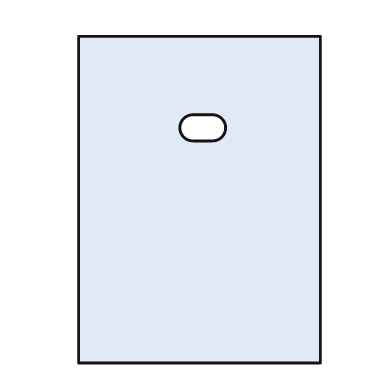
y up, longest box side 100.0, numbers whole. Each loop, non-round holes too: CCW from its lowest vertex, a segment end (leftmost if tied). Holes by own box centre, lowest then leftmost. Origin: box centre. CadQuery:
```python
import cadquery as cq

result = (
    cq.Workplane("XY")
    .moveTo(-37.0, -50.0)
    .lineTo(37.0, -50.0)
    .lineTo(37.0, 50.0)
    .lineTo(-37.0, 50.0)
    .close()
    .moveTo(-2.0, 18.0)
    .lineTo(4.0, 18.0)
    .threePointArc((8.0, 22.0), (4.0, 26.0))
    .lineTo(-2.0, 26.0)
    .threePointArc((-6.0, 22.0), (-2.0, 18.0))
    .close()
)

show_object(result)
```